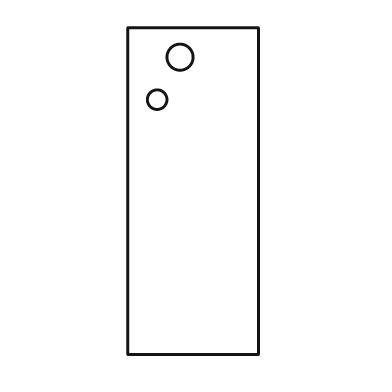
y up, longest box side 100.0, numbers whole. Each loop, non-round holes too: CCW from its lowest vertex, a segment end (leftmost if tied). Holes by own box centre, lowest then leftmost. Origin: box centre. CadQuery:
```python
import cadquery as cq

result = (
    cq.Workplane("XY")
    .moveTo(-20.0, -50.0)
    .lineTo(20.0, -50.0)
    .lineTo(20.0, 50.0)
    .lineTo(-20.0, 50.0)
    .close()
    .moveTo(-11.0, 28.0)
    .circle(3.0)
    .moveTo(-4.0, 41.0)
    .circle(4.0)
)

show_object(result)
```